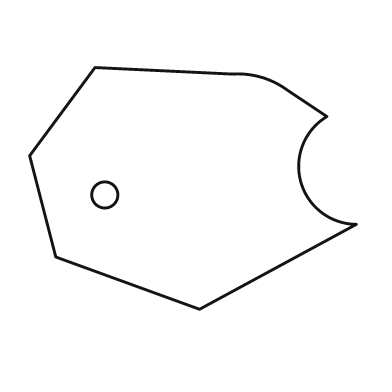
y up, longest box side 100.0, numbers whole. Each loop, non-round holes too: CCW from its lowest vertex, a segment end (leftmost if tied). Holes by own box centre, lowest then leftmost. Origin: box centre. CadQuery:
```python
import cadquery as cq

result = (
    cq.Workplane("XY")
    .moveTo(2.0, -37.0)
    .lineTo(50.0, -11.0)
    .threePointArc((33.0, 2.0), (41.0, 22.0))
    .lineTo(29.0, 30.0)
    .threePointArc((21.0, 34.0), (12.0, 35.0))
    .lineTo(-30.0, 37.0)
    .lineTo(-50.0, 10.0)
    .lineTo(-42.0, -21.0)
    .close()
    .moveTo(-27.0, -2.0)
    .circle(4.0)
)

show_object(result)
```